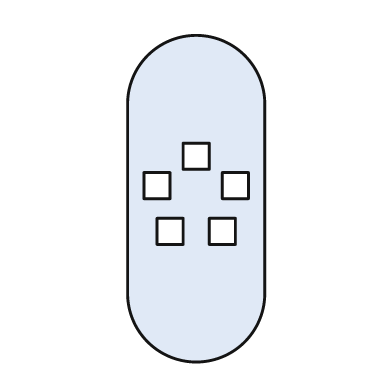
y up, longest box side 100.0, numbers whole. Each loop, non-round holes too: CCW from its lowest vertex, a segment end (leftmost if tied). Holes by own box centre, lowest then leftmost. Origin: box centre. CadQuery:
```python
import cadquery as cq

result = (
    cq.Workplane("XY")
    .moveTo(-21.0, -29.0)
    .threePointArc((0.0, -50.0), (21.0, -29.0))
    .lineTo(21.0, 29.0)
    .threePointArc((0.0, 50.0), (-21.0, 29.0))
    .close()
    .moveTo(-12.0, -14.0)
    .lineTo(-4.0, -14.0)
    .lineTo(-4.0, -6.0)
    .lineTo(-12.0, -6.0)
    .close()
    .moveTo(4.0, -14.0)
    .lineTo(12.0, -14.0)
    .lineTo(12.0, -6.0)
    .lineTo(4.0, -6.0)
    .close()
    .moveTo(-16.0, 0.0)
    .lineTo(-8.0, 0.0)
    .lineTo(-8.0, 8.0)
    .lineTo(-16.0, 8.0)
    .close()
    .moveTo(8.0, 0.0)
    .lineTo(16.0, 0.0)
    .lineTo(16.0, 8.0)
    .lineTo(8.0, 8.0)
    .close()
    .moveTo(-4.0, 9.0)
    .lineTo(4.0, 9.0)
    .lineTo(4.0, 17.0)
    .lineTo(-4.0, 17.0)
    .close()
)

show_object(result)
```